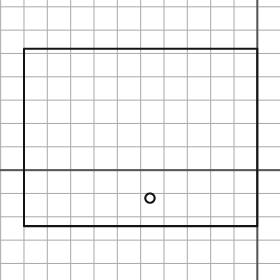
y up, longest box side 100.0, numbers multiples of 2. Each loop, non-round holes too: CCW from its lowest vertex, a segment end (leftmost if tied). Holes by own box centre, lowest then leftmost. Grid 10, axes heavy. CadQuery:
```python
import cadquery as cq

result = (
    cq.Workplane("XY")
    .moveTo(-100.0, -24.0)
    .lineTo(0.0, -24.0)
    .lineTo(0.0, 52.0)
    .lineTo(-100.0, 52.0)
    .close()
    .moveTo(-46.0, -12.0)
    .circle(2.0)
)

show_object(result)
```